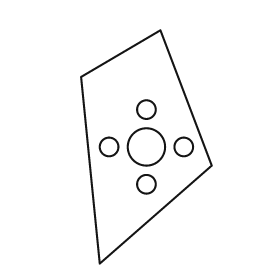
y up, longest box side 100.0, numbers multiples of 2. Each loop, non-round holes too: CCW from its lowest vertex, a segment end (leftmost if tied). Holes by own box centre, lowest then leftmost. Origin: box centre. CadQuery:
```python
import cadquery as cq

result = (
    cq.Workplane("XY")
    .moveTo(-20.0, -50.0)
    .lineTo(28.0, -8.0)
    .lineTo(6.0, 50.0)
    .lineTo(-28.0, 30.0)
    .close()
    .moveTo(0.0, -16.0)
    .circle(4.0)
    .moveTo(-16.0, 0.0)
    .circle(4.0)
    .moveTo(0.0, 0.0)
    .circle(8.0)
    .moveTo(16.0, 0.0)
    .circle(4.0)
    .moveTo(0.0, 16.0)
    .circle(4.0)
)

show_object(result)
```